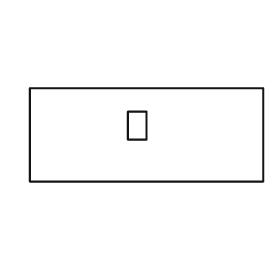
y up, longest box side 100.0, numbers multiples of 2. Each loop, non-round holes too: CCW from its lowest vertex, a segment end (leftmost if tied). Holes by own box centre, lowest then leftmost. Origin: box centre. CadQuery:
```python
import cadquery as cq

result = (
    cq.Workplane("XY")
    .moveTo(-50.0, -20.0)
    .lineTo(50.0, -20.0)
    .lineTo(50.0, 20.0)
    .lineTo(-50.0, 20.0)
    .close()
    .moveTo(-8.0, -2.0)
    .lineTo(0.0, -2.0)
    .lineTo(0.0, 10.0)
    .lineTo(-8.0, 10.0)
    .close()
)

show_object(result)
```